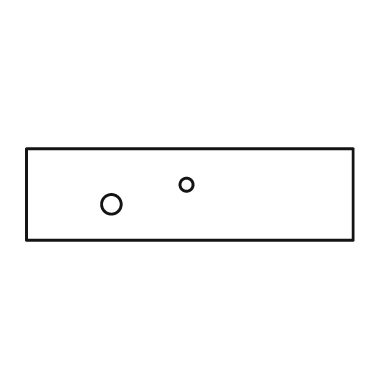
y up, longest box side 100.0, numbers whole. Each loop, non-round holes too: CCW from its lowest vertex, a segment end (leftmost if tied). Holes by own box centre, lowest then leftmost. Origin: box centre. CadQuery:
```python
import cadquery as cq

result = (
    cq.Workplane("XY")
    .moveTo(-50.0, -14.0)
    .lineTo(50.0, -14.0)
    .lineTo(50.0, 14.0)
    .lineTo(-50.0, 14.0)
    .close()
    .moveTo(-24.0, -3.0)
    .circle(3.0)
    .moveTo(-1.0, 3.0)
    .circle(2.0)
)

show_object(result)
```